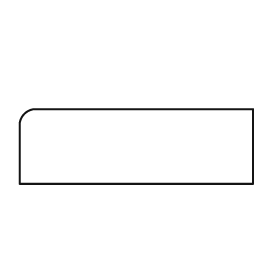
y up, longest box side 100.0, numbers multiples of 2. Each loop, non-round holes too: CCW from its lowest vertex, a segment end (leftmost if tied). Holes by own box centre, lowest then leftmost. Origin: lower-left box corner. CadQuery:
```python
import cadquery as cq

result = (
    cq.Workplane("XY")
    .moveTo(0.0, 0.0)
    .lineTo(100.0, 0.0)
    .lineTo(100.0, 32.0)
    .lineTo(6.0, 32.0)
    .threePointArc((2.0, 30.0), (0.0, 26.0))
    .close()
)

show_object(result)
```